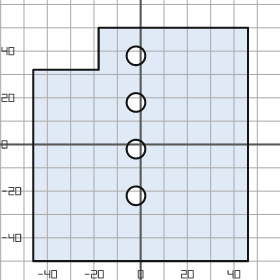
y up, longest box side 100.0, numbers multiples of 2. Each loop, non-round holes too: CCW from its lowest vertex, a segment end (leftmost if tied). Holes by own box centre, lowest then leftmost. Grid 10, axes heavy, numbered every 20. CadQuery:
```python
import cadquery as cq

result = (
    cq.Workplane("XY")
    .moveTo(-46.0, -50.0)
    .lineTo(46.0, -50.0)
    .lineTo(46.0, 50.0)
    .lineTo(-18.0, 50.0)
    .lineTo(-18.0, 32.0)
    .lineTo(-46.0, 32.0)
    .close()
    .moveTo(-2.0, -22.0)
    .circle(4.0)
    .moveTo(-2.0, -2.0)
    .circle(4.0)
    .moveTo(-2.0, 18.0)
    .circle(4.0)
    .moveTo(-2.0, 38.0)
    .circle(4.0)
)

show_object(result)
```